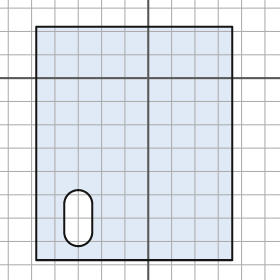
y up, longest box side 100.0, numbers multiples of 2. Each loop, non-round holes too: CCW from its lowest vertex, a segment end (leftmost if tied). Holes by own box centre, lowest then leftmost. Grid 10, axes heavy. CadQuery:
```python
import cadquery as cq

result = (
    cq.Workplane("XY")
    .moveTo(-48.0, -78.0)
    .lineTo(36.0, -78.0)
    .lineTo(36.0, 22.0)
    .lineTo(-48.0, 22.0)
    .close()
    .moveTo(-36.0, -66.0)
    .threePointArc((-30.0, -72.0), (-24.0, -66.0))
    .lineTo(-24.0, -54.0)
    .threePointArc((-30.0, -48.0), (-36.0, -54.0))
    .close()
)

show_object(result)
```